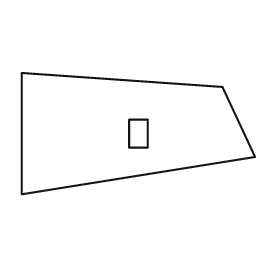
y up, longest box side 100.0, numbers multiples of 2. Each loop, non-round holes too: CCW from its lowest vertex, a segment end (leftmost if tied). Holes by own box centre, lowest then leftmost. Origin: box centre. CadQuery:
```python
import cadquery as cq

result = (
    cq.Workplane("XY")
    .moveTo(-50.0, -26.0)
    .lineTo(50.0, -10.0)
    .lineTo(36.0, 20.0)
    .lineTo(-50.0, 26.0)
    .close()
    .moveTo(-4.0, -6.0)
    .lineTo(4.0, -6.0)
    .lineTo(4.0, 6.0)
    .lineTo(-4.0, 6.0)
    .close()
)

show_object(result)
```